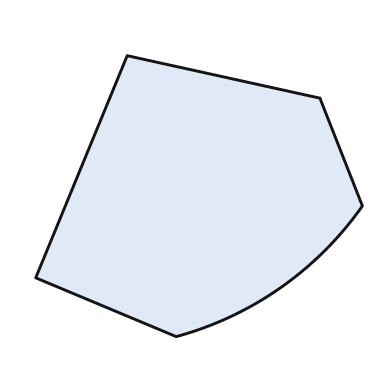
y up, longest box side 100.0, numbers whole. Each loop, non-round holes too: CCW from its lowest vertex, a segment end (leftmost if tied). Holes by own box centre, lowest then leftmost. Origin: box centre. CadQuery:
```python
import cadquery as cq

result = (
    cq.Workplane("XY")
    .moveTo(-7.0, -43.0)
    .threePointArc((25.0, -28.0), (50.0, -3.0))
    .lineTo(37.0, 30.0)
    .lineTo(-22.0, 43.0)
    .lineTo(-50.0, -25.0)
    .close()
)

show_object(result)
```